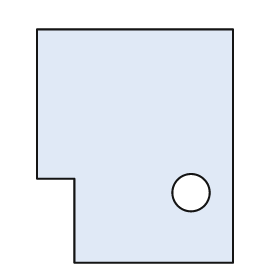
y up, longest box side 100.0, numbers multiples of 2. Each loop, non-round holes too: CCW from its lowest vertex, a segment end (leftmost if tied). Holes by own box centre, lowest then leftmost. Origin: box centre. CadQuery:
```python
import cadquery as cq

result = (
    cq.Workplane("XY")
    .moveTo(-26.0, -50.0)
    .lineTo(42.0, -50.0)
    .lineTo(42.0, 50.0)
    .lineTo(-42.0, 50.0)
    .lineTo(-42.0, -14.0)
    .lineTo(-26.0, -14.0)
    .close()
    .moveTo(24.0, -20.0)
    .circle(8.0)
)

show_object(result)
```